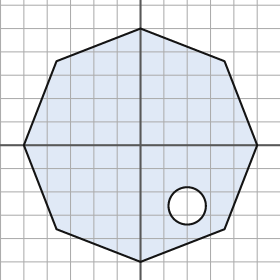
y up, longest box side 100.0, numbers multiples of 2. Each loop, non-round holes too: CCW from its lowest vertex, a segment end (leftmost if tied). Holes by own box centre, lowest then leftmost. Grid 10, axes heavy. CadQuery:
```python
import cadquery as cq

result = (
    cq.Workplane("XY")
    .moveTo(0.0, -50.0)
    .lineTo(36.0, -36.0)
    .lineTo(50.0, 0.0)
    .lineTo(36.0, 36.0)
    .lineTo(0.0, 50.0)
    .lineTo(-36.0, 36.0)
    .lineTo(-50.0, 0.0)
    .lineTo(-36.0, -36.0)
    .close()
    .moveTo(20.0, -26.0)
    .circle(8.0)
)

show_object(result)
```